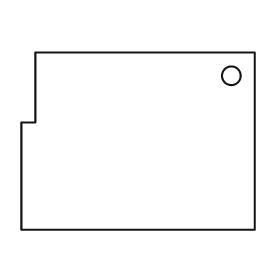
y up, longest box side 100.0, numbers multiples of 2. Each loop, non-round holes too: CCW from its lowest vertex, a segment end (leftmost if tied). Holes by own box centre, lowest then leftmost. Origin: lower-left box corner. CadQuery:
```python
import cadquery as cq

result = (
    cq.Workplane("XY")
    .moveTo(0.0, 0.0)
    .lineTo(100.0, 0.0)
    .lineTo(100.0, 76.0)
    .lineTo(6.0, 76.0)
    .lineTo(6.0, 46.0)
    .lineTo(0.0, 46.0)
    .close()
    .moveTo(90.0, 66.0)
    .circle(4.0)
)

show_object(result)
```